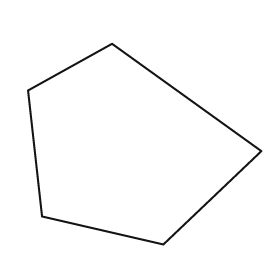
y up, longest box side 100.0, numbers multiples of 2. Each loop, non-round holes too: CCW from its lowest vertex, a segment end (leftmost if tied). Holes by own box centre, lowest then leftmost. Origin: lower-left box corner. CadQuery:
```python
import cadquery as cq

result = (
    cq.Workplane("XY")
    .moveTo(58.0, 0.0)
    .lineTo(100.0, 40.0)
    .lineTo(36.0, 86.0)
    .lineTo(0.0, 66.0)
    .lineTo(6.0, 12.0)
    .close()
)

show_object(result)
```